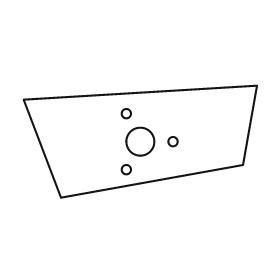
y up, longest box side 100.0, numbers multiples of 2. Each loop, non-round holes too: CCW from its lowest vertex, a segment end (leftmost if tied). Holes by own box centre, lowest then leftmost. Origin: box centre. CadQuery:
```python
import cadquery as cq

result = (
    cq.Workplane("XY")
    .moveTo(-34.0, -24.0)
    .lineTo(44.0, -10.0)
    .lineTo(50.0, 24.0)
    .lineTo(-50.0, 18.0)
    .close()
    .moveTo(-6.0, -12.0)
    .circle(2.0)
    .moveTo(0.0, 0.0)
    .circle(6.0)
    .moveTo(14.0, 0.0)
    .circle(2.0)
    .moveTo(-6.0, 12.0)
    .circle(2.0)
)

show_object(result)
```